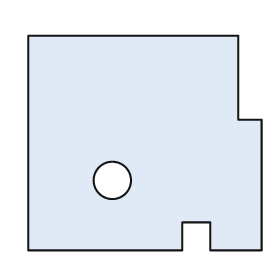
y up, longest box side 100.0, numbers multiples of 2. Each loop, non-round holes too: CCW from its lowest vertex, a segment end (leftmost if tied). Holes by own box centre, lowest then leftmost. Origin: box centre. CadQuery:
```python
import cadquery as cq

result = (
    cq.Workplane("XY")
    .moveTo(-50.0, -46.0)
    .lineTo(16.0, -46.0)
    .lineTo(16.0, -34.0)
    .lineTo(28.0, -34.0)
    .lineTo(28.0, -46.0)
    .lineTo(50.0, -46.0)
    .lineTo(50.0, 10.0)
    .lineTo(40.0, 10.0)
    .lineTo(40.0, 46.0)
    .lineTo(-50.0, 46.0)
    .close()
    .moveTo(-14.0, -16.0)
    .circle(8.0)
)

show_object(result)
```